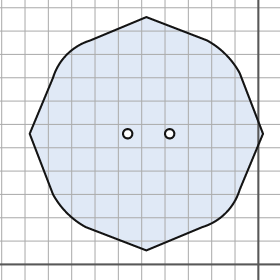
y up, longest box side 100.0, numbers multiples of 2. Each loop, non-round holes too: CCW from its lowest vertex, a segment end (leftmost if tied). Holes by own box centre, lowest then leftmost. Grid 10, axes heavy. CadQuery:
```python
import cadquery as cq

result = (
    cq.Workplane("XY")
    .moveTo(-48.0, 6.0)
    .lineTo(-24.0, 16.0)
    .threePointArc((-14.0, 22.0), (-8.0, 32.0))
    .lineTo(2.0, 56.0)
    .lineTo(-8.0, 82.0)
    .threePointArc((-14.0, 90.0), (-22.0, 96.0))
    .lineTo(-48.0, 106.0)
    .lineTo(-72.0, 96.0)
    .threePointArc((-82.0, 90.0), (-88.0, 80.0))
    .lineTo(-98.0, 56.0)
    .lineTo(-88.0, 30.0)
    .threePointArc((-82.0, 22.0), (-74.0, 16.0))
    .close()
    .moveTo(-56.0, 56.0)
    .circle(2.0)
    .moveTo(-38.0, 56.0)
    .circle(2.0)
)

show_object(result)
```